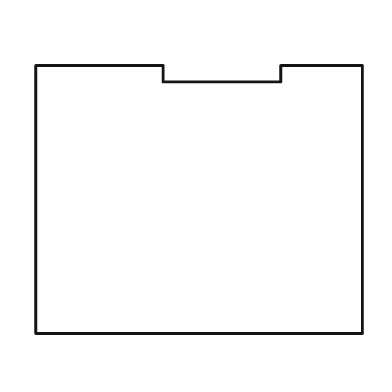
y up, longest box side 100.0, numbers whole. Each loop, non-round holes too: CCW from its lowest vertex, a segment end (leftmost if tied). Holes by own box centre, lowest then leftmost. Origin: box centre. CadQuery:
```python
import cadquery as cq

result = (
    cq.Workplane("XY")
    .moveTo(-50.0, -41.0)
    .lineTo(50.0, -41.0)
    .lineTo(50.0, 41.0)
    .lineTo(25.0, 41.0)
    .lineTo(25.0, 36.0)
    .lineTo(-11.0, 36.0)
    .lineTo(-11.0, 41.0)
    .lineTo(-50.0, 41.0)
    .close()
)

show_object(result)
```